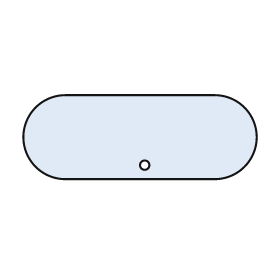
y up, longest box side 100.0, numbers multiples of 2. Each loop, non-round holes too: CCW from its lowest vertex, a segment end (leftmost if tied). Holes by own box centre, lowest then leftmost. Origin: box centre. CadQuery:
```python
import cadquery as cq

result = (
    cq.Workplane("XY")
    .moveTo(-32.0, -18.0)
    .lineTo(32.0, -18.0)
    .threePointArc((50.0, 0.0), (32.0, 18.0))
    .lineTo(-32.0, 18.0)
    .threePointArc((-50.0, 0.0), (-32.0, -18.0))
    .close()
    .moveTo(2.0, -12.0)
    .circle(2.0)
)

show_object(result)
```